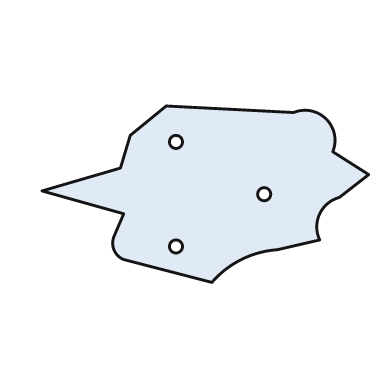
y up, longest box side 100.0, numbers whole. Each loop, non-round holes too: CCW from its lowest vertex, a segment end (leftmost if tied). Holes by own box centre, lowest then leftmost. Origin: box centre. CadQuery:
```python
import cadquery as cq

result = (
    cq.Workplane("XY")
    .moveTo(2.0, -27.0)
    .threePointArc((11.0, -20.0), (22.0, -17.0))
    .lineTo(35.0, -14.0)
    .threePointArc((35.0, -6.0), (41.0, -1.0))
    .lineTo(50.0, 6.0)
    .lineTo(39.0, 13.0)
    .threePointArc((37.0, 23.0), (27.0, 25.0))
    .lineTo(-12.0, 27.0)
    .lineTo(-23.0, 18.0)
    .lineTo(-26.0, 8.0)
    .lineTo(-50.0, 1.0)
    .lineTo(-25.0, -6.0)
    .lineTo(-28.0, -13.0)
    .threePointArc((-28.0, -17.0), (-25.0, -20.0))
    .close()
    .moveTo(-9.0, -16.0)
    .circle(2.0)
    .moveTo(18.0, 0.0)
    .circle(2.0)
    .moveTo(-9.0, 16.0)
    .circle(2.0)
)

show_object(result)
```